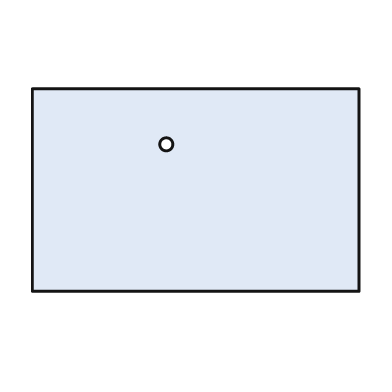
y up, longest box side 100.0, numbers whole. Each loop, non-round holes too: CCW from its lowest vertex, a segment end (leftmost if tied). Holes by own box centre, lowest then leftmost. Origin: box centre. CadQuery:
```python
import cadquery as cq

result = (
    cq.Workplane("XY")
    .moveTo(-50.0, -31.0)
    .lineTo(50.0, -31.0)
    .lineTo(50.0, 31.0)
    .lineTo(-50.0, 31.0)
    .close()
    .moveTo(-9.0, 14.0)
    .circle(2.0)
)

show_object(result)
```